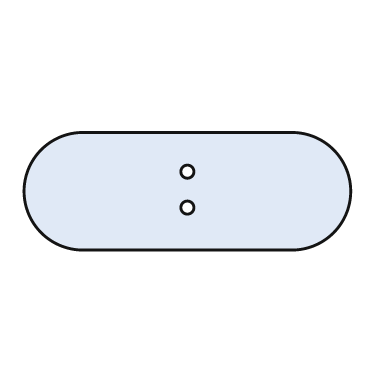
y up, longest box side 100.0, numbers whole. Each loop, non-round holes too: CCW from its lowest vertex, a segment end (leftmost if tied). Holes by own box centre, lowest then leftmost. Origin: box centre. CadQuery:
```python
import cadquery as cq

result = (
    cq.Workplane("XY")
    .moveTo(-32.0, -18.0)
    .lineTo(32.0, -18.0)
    .threePointArc((50.0, 0.0), (32.0, 18.0))
    .lineTo(-32.0, 18.0)
    .threePointArc((-50.0, 0.0), (-32.0, -18.0))
    .close()
    .moveTo(0.0, -5.0)
    .circle(2.0)
    .moveTo(0.0, 6.0)
    .circle(2.0)
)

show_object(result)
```